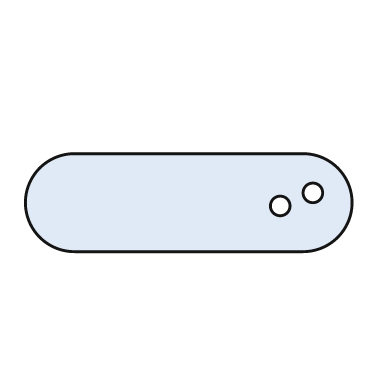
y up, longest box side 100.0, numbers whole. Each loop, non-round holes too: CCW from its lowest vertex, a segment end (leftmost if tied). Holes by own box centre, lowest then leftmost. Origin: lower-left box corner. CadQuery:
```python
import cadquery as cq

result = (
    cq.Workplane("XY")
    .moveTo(15.0, 0.0)
    .lineTo(85.0, 0.0)
    .threePointArc((100.0, 15.0), (85.0, 30.0))
    .lineTo(15.0, 30.0)
    .threePointArc((0.0, 15.0), (15.0, 0.0))
    .close()
    .moveTo(78.0, 14.0)
    .circle(3.0)
    .moveTo(88.0, 18.0)
    .circle(3.0)
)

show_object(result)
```